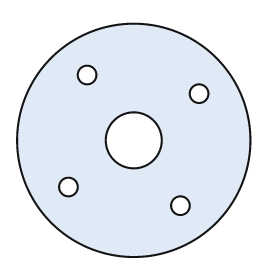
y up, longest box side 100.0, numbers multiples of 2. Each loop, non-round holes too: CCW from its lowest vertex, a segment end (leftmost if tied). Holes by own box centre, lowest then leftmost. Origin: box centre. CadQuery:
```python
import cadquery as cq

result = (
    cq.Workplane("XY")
    .moveTo(0.0, 0.0)
    .circle(50.0)
    .moveTo(20.0, -28.0)
    .circle(4.0)
    .moveTo(-28.0, -20.0)
    .circle(4.0)
    .moveTo(0.0, 0.0)
    .circle(12.0)
    .moveTo(28.0, 20.0)
    .circle(4.0)
    .moveTo(-20.0, 28.0)
    .circle(4.0)
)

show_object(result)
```